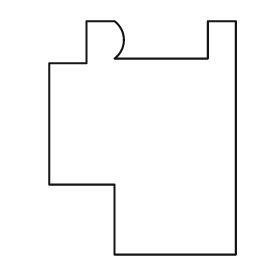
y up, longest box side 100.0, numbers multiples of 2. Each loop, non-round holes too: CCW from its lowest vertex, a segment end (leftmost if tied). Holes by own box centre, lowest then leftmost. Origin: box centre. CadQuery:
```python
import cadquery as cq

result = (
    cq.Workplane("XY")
    .moveTo(-12.0, -50.0)
    .lineTo(40.0, -50.0)
    .lineTo(40.0, 50.0)
    .lineTo(28.0, 50.0)
    .lineTo(28.0, 34.0)
    .lineTo(-12.0, 34.0)
    .threePointArc((-8.0, 42.0), (-12.0, 50.0))
    .lineTo(-24.0, 50.0)
    .lineTo(-24.0, 32.0)
    .lineTo(-40.0, 32.0)
    .lineTo(-40.0, -20.0)
    .lineTo(-12.0, -20.0)
    .close()
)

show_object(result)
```